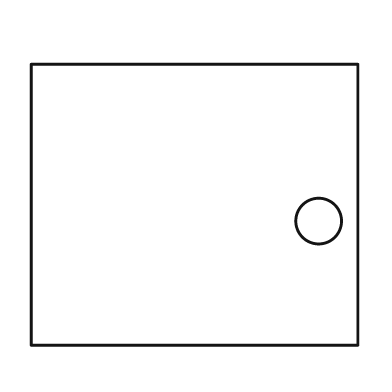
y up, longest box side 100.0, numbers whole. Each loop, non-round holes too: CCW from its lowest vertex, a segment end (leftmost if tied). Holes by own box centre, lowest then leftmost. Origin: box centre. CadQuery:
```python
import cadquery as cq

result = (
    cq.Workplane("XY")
    .moveTo(-50.0, -43.0)
    .lineTo(50.0, -43.0)
    .lineTo(50.0, 43.0)
    .lineTo(-50.0, 43.0)
    .close()
    .moveTo(38.0, -5.0)
    .circle(7.0)
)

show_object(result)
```